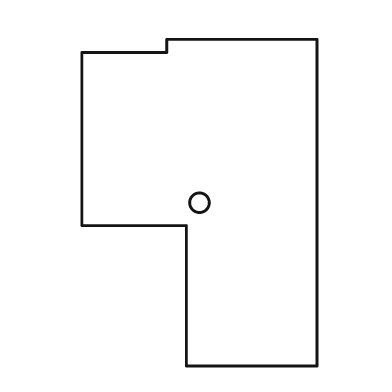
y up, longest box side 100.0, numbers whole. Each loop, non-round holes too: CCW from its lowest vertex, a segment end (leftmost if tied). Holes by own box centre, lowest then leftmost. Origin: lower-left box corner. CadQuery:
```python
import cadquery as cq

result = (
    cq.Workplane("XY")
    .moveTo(32.0, 0.0)
    .lineTo(72.0, 0.0)
    .lineTo(72.0, 100.0)
    .lineTo(26.0, 100.0)
    .lineTo(26.0, 96.0)
    .lineTo(0.0, 96.0)
    .lineTo(0.0, 43.0)
    .lineTo(32.0, 43.0)
    .close()
    .moveTo(36.0, 50.0)
    .circle(3.0)
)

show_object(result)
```